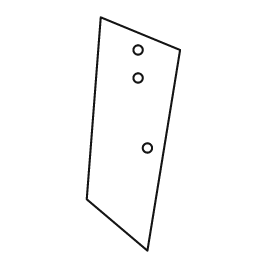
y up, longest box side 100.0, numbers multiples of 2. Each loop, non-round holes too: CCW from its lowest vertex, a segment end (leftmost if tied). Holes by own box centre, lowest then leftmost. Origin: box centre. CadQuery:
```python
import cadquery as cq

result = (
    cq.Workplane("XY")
    .moveTo(6.0, -50.0)
    .lineTo(20.0, 36.0)
    .lineTo(-14.0, 50.0)
    .lineTo(-20.0, -28.0)
    .close()
    .moveTo(6.0, -6.0)
    .circle(2.0)
    .moveTo(2.0, 24.0)
    .circle(2.0)
    .moveTo(2.0, 36.0)
    .circle(2.0)
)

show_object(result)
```